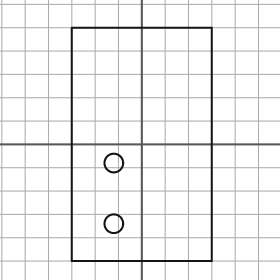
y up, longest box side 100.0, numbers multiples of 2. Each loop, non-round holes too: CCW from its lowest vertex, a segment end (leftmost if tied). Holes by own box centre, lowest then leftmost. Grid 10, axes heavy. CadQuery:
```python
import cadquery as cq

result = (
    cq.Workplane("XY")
    .moveTo(-30.0, -50.0)
    .lineTo(30.0, -50.0)
    .lineTo(30.0, 50.0)
    .lineTo(-30.0, 50.0)
    .close()
    .moveTo(-12.0, -34.0)
    .circle(4.0)
    .moveTo(-12.0, -8.0)
    .circle(4.0)
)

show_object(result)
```